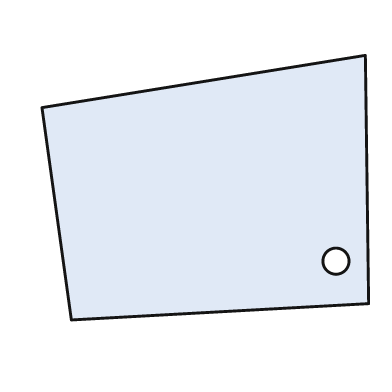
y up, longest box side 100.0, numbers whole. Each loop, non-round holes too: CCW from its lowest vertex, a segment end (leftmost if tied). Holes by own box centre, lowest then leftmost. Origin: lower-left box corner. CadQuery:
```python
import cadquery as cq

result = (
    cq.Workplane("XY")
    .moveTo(9.0, 0.0)
    .lineTo(100.0, 5.0)
    .lineTo(99.0, 81.0)
    .lineTo(0.0, 65.0)
    .close()
    .moveTo(90.0, 18.0)
    .circle(4.0)
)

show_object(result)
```